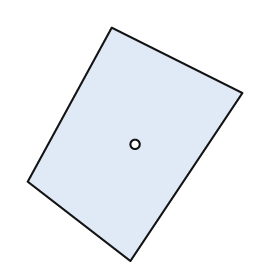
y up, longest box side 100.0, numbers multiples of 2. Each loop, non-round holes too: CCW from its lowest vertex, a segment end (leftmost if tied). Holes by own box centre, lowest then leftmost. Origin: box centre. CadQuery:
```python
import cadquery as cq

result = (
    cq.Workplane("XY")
    .moveTo(-2.0, -50.0)
    .lineTo(46.0, 22.0)
    .lineTo(-10.0, 50.0)
    .lineTo(-46.0, -16.0)
    .close()
    .moveTo(0.0, 0.0)
    .circle(2.0)
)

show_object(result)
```